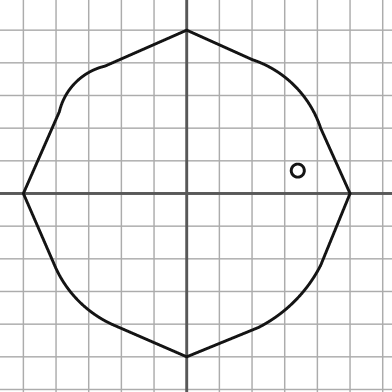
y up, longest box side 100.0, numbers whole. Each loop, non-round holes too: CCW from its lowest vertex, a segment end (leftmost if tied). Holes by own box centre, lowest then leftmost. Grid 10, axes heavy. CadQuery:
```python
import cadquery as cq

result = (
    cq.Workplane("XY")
    .moveTo(0.0, -50.0)
    .lineTo(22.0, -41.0)
    .threePointArc((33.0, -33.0), (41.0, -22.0))
    .lineTo(50.0, 0.0)
    .lineTo(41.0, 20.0)
    .threePointArc((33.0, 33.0), (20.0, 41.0))
    .lineTo(0.0, 50.0)
    .lineTo(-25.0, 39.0)
    .threePointArc((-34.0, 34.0), (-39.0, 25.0))
    .lineTo(-50.0, 0.0)
    .lineTo(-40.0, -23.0)
    .threePointArc((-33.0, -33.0), (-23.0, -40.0))
    .close()
    .moveTo(34.0, 7.0)
    .circle(2.0)
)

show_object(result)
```